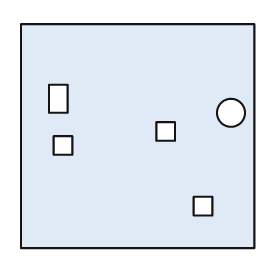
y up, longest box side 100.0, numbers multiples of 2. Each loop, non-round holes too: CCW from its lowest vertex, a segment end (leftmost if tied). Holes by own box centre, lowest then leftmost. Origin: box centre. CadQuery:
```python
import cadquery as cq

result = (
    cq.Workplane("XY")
    .moveTo(-50.0, -48.0)
    .lineTo(50.0, -48.0)
    .lineTo(50.0, 48.0)
    .lineTo(-50.0, 48.0)
    .close()
    .moveTo(24.0, -34.0)
    .lineTo(32.0, -34.0)
    .lineTo(32.0, -26.0)
    .lineTo(24.0, -26.0)
    .close()
    .moveTo(-36.0, -8.0)
    .lineTo(-28.0, -8.0)
    .lineTo(-28.0, 0.0)
    .lineTo(-36.0, 0.0)
    .close()
    .moveTo(8.0, -2.0)
    .lineTo(16.0, -2.0)
    .lineTo(16.0, 6.0)
    .lineTo(8.0, 6.0)
    .close()
    .moveTo(40.0, 10.0)
    .circle(6.0)
    .moveTo(-38.0, 10.0)
    .lineTo(-30.0, 10.0)
    .lineTo(-30.0, 22.0)
    .lineTo(-38.0, 22.0)
    .close()
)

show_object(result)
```